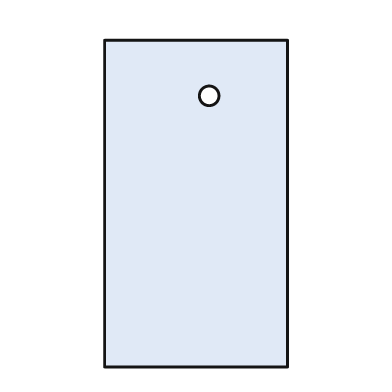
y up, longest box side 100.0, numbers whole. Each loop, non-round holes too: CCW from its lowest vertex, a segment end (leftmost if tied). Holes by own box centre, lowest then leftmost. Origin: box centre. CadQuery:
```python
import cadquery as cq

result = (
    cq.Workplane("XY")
    .moveTo(-28.0, -50.0)
    .lineTo(28.0, -50.0)
    .lineTo(28.0, 50.0)
    .lineTo(-28.0, 50.0)
    .close()
    .moveTo(4.0, 33.0)
    .circle(3.0)
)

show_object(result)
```